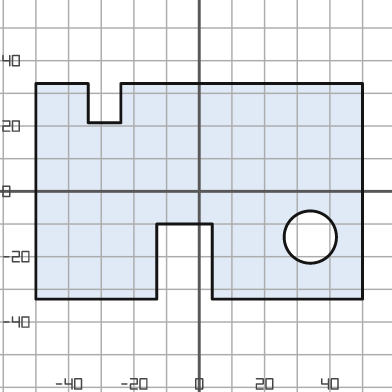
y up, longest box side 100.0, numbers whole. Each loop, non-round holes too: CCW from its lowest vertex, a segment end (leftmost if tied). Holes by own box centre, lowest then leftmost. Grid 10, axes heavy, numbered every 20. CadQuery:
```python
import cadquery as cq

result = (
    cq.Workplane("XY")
    .moveTo(-50.0, -33.0)
    .lineTo(-13.0, -33.0)
    .lineTo(-13.0, -10.0)
    .lineTo(4.0, -10.0)
    .lineTo(4.0, -33.0)
    .lineTo(50.0, -33.0)
    .lineTo(50.0, 33.0)
    .lineTo(-24.0, 33.0)
    .lineTo(-24.0, 21.0)
    .lineTo(-34.0, 21.0)
    .lineTo(-34.0, 33.0)
    .lineTo(-50.0, 33.0)
    .close()
    .moveTo(34.0, -14.0)
    .circle(8.0)
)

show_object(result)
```